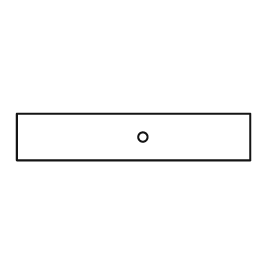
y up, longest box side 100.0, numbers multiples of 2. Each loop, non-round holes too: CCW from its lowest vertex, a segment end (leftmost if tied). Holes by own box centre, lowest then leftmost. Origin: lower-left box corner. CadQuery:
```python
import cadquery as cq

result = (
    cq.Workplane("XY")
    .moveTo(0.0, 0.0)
    .lineTo(100.0, 0.0)
    .lineTo(100.0, 20.0)
    .lineTo(0.0, 20.0)
    .close()
    .moveTo(54.0, 10.0)
    .circle(2.0)
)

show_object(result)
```